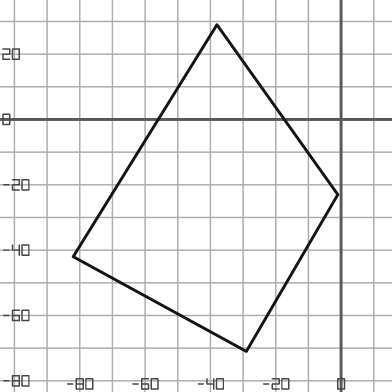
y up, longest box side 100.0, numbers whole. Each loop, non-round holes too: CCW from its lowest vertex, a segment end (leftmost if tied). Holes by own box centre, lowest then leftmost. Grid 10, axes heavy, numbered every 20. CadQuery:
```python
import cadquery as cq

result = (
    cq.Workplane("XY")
    .moveTo(-29.0, -71.0)
    .lineTo(-1.0, -23.0)
    .lineTo(-38.0, 29.0)
    .lineTo(-82.0, -42.0)
    .close()
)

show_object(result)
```